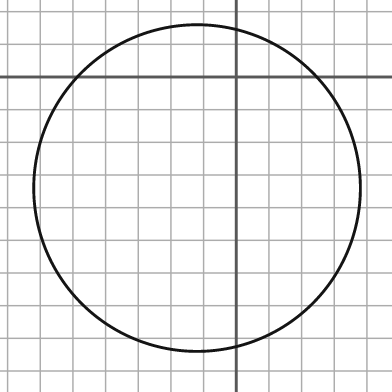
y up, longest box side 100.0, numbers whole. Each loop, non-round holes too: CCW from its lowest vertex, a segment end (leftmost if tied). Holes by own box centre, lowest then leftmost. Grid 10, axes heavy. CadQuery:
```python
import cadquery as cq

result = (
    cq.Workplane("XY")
    .moveTo(-12.0, -34.0)
    .circle(50.0)
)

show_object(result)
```